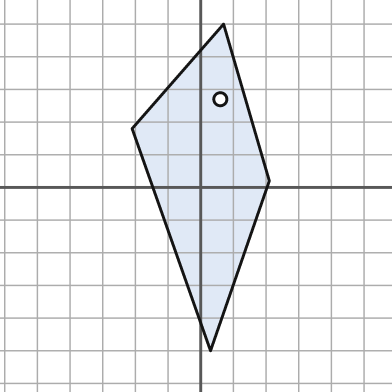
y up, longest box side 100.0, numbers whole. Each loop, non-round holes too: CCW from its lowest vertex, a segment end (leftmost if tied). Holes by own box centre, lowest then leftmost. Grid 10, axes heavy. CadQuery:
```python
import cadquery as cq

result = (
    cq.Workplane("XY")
    .moveTo(3.0, -50.0)
    .lineTo(21.0, 2.0)
    .lineTo(7.0, 50.0)
    .lineTo(-21.0, 18.0)
    .close()
    .moveTo(6.0, 27.0)
    .circle(2.0)
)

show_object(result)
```